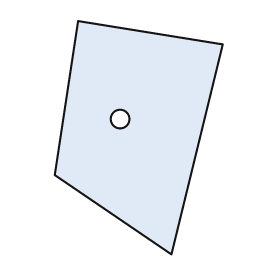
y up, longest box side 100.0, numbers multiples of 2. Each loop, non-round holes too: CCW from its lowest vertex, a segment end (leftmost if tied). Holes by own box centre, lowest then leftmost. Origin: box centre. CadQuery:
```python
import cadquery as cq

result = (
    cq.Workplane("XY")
    .moveTo(14.0, -50.0)
    .lineTo(36.0, 40.0)
    .lineTo(-26.0, 50.0)
    .lineTo(-36.0, -16.0)
    .close()
    .moveTo(-8.0, 8.0)
    .circle(4.0)
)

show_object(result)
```